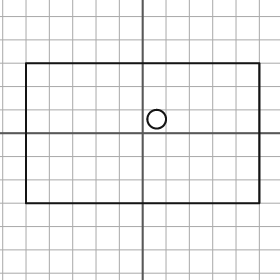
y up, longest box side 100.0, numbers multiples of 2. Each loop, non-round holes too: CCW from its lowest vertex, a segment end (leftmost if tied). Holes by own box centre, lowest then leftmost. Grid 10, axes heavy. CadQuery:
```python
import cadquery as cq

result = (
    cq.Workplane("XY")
    .moveTo(-50.0, -30.0)
    .lineTo(50.0, -30.0)
    .lineTo(50.0, 30.0)
    .lineTo(-50.0, 30.0)
    .close()
    .moveTo(6.0, 6.0)
    .circle(4.0)
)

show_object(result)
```